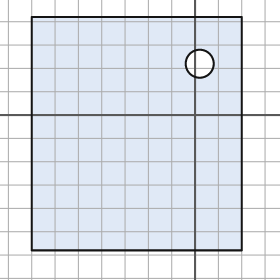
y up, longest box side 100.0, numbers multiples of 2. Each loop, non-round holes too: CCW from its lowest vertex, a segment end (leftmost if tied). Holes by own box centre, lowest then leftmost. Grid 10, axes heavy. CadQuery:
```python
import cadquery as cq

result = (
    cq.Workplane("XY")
    .moveTo(-70.0, -58.0)
    .lineTo(20.0, -58.0)
    .lineTo(20.0, 42.0)
    .lineTo(-70.0, 42.0)
    .close()
    .moveTo(2.0, 22.0)
    .circle(6.0)
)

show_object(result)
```